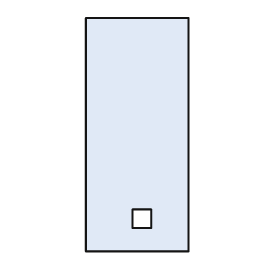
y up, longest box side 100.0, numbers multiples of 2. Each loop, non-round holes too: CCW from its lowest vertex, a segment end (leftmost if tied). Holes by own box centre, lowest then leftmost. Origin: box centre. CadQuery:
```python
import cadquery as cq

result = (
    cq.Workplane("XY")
    .moveTo(-22.0, -50.0)
    .lineTo(22.0, -50.0)
    .lineTo(22.0, 50.0)
    .lineTo(-22.0, 50.0)
    .close()
    .moveTo(-2.0, -40.0)
    .lineTo(6.0, -40.0)
    .lineTo(6.0, -32.0)
    .lineTo(-2.0, -32.0)
    .close()
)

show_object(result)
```